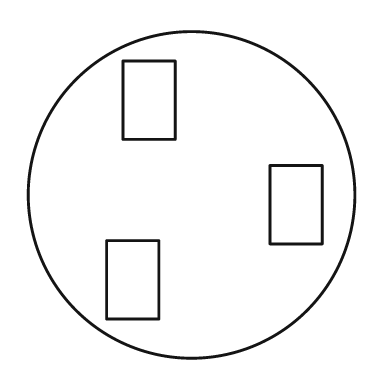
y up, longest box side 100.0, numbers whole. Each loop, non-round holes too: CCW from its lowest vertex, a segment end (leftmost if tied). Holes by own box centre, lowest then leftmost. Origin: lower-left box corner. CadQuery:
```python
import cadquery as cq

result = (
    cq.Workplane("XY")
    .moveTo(50.0, 50.0)
    .circle(50.0)
    .moveTo(24.0, 12.0)
    .lineTo(40.0, 12.0)
    .lineTo(40.0, 36.0)
    .lineTo(24.0, 36.0)
    .close()
    .moveTo(74.0, 35.0)
    .lineTo(90.0, 35.0)
    .lineTo(90.0, 59.0)
    .lineTo(74.0, 59.0)
    .close()
    .moveTo(29.0, 67.0)
    .lineTo(45.0, 67.0)
    .lineTo(45.0, 91.0)
    .lineTo(29.0, 91.0)
    .close()
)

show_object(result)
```